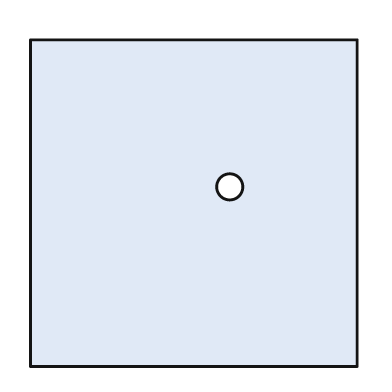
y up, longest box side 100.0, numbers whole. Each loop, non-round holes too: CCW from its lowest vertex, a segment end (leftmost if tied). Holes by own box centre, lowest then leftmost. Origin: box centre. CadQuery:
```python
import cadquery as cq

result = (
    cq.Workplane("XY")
    .moveTo(-50.0, -50.0)
    .lineTo(50.0, -50.0)
    .lineTo(50.0, 50.0)
    .lineTo(-50.0, 50.0)
    .close()
    .moveTo(11.0, 5.0)
    .circle(4.0)
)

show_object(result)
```